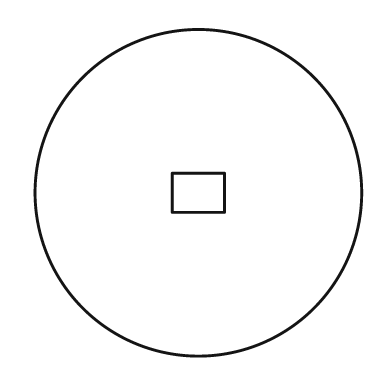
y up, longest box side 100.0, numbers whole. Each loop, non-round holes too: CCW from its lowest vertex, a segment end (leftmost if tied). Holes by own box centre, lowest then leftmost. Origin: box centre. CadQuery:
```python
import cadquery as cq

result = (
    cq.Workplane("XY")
    .moveTo(0.0, 0.0)
    .circle(50.0)
    .moveTo(-8.0, -6.0)
    .lineTo(8.0, -6.0)
    .lineTo(8.0, 6.0)
    .lineTo(-8.0, 6.0)
    .close()
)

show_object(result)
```